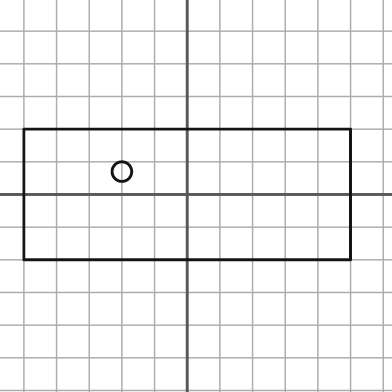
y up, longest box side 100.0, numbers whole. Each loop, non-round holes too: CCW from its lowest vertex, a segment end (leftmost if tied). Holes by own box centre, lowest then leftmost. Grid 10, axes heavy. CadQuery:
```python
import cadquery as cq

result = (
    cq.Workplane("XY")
    .moveTo(-50.0, -20.0)
    .lineTo(50.0, -20.0)
    .lineTo(50.0, 20.0)
    .lineTo(-50.0, 20.0)
    .close()
    .moveTo(-20.0, 7.0)
    .circle(3.0)
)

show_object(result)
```